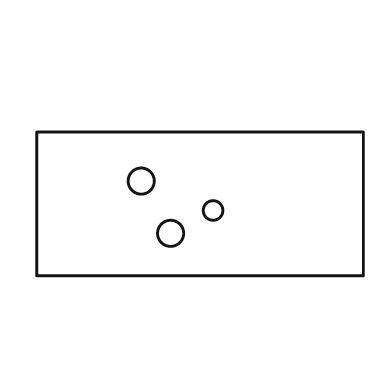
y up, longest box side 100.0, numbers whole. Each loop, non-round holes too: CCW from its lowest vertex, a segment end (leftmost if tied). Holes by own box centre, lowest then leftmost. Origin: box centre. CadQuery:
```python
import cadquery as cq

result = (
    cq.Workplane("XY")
    .moveTo(-50.0, -22.0)
    .lineTo(50.0, -22.0)
    .lineTo(50.0, 22.0)
    .lineTo(-50.0, 22.0)
    .close()
    .moveTo(-9.0, -9.0)
    .circle(4.0)
    .moveTo(4.0, -2.0)
    .circle(3.0)
    .moveTo(-18.0, 7.0)
    .circle(4.0)
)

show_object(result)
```